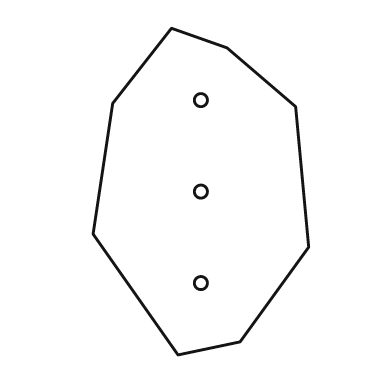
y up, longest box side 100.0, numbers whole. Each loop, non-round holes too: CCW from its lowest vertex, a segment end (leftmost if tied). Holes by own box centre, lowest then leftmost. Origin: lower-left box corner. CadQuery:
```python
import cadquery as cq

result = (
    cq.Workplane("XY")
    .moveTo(26.0, 0.0)
    .lineTo(45.0, 4.0)
    .lineTo(66.0, 33.0)
    .lineTo(62.0, 76.0)
    .lineTo(41.0, 94.0)
    .lineTo(24.0, 100.0)
    .lineTo(6.0, 77.0)
    .lineTo(0.0, 37.0)
    .close()
    .moveTo(33.0, 22.0)
    .circle(2.0)
    .moveTo(33.0, 50.0)
    .circle(2.0)
    .moveTo(33.0, 78.0)
    .circle(2.0)
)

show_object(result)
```